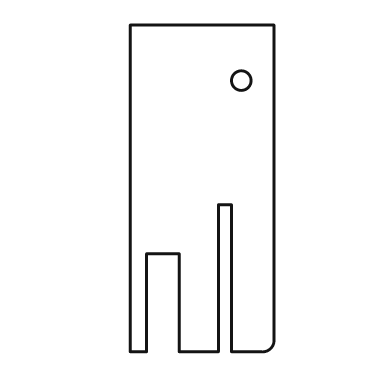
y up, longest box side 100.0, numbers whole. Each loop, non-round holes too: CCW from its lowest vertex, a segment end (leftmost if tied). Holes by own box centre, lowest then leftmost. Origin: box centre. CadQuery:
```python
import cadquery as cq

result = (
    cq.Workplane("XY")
    .moveTo(-22.0, -50.0)
    .lineTo(-17.0, -50.0)
    .lineTo(-17.0, -20.0)
    .lineTo(-7.0, -20.0)
    .lineTo(-7.0, -50.0)
    .lineTo(5.0, -50.0)
    .lineTo(5.0, -5.0)
    .lineTo(9.0, -5.0)
    .lineTo(9.0, -50.0)
    .lineTo(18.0, -50.0)
    .threePointArc((21.0, -49.0), (22.0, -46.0))
    .lineTo(22.0, 50.0)
    .lineTo(-22.0, 50.0)
    .close()
    .moveTo(12.0, 33.0)
    .circle(3.0)
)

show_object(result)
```